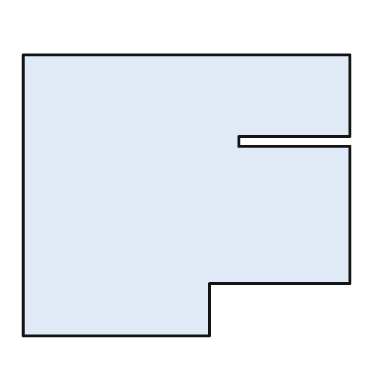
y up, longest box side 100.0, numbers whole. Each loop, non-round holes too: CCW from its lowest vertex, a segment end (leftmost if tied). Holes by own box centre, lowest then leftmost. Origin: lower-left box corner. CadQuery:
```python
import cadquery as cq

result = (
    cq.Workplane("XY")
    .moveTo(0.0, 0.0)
    .lineTo(57.0, 0.0)
    .lineTo(57.0, 16.0)
    .lineTo(100.0, 16.0)
    .lineTo(100.0, 58.0)
    .lineTo(66.0, 58.0)
    .lineTo(66.0, 61.0)
    .lineTo(100.0, 61.0)
    .lineTo(100.0, 86.0)
    .lineTo(0.0, 86.0)
    .close()
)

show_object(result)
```